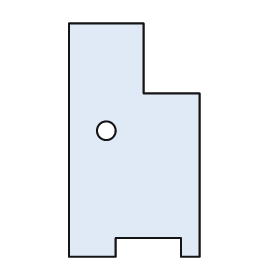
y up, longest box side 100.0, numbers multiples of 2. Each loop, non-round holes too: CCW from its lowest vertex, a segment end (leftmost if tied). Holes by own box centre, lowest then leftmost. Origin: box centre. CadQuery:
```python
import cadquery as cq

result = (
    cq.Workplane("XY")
    .moveTo(-28.0, -50.0)
    .lineTo(-8.0, -50.0)
    .lineTo(-8.0, -42.0)
    .lineTo(20.0, -42.0)
    .lineTo(20.0, -50.0)
    .lineTo(28.0, -50.0)
    .lineTo(28.0, 20.0)
    .lineTo(4.0, 20.0)
    .lineTo(4.0, 50.0)
    .lineTo(-28.0, 50.0)
    .close()
    .moveTo(-12.0, 4.0)
    .circle(4.0)
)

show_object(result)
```